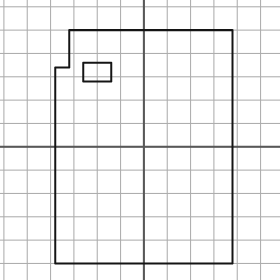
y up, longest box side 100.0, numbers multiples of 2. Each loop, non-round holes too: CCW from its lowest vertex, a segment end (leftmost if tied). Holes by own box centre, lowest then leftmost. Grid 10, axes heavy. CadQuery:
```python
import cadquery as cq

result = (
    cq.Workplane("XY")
    .moveTo(-38.0, -50.0)
    .lineTo(38.0, -50.0)
    .lineTo(38.0, 50.0)
    .lineTo(-32.0, 50.0)
    .lineTo(-32.0, 34.0)
    .lineTo(-38.0, 34.0)
    .close()
    .moveTo(-26.0, 28.0)
    .lineTo(-14.0, 28.0)
    .lineTo(-14.0, 36.0)
    .lineTo(-26.0, 36.0)
    .close()
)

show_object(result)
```